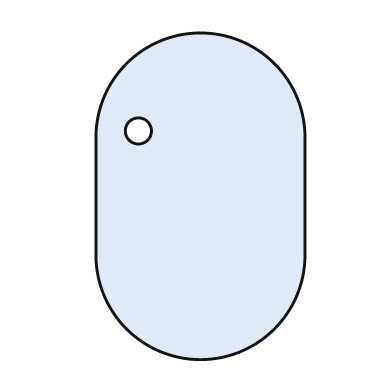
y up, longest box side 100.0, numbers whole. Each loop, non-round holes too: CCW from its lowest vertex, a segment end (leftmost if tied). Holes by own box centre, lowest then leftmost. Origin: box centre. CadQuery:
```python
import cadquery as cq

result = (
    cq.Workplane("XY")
    .moveTo(-32.0, -18.0)
    .threePointArc((0.0, -50.0), (32.0, -18.0))
    .lineTo(32.0, 18.0)
    .threePointArc((0.0, 50.0), (-32.0, 18.0))
    .close()
    .moveTo(-19.0, 20.0)
    .circle(4.0)
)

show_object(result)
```